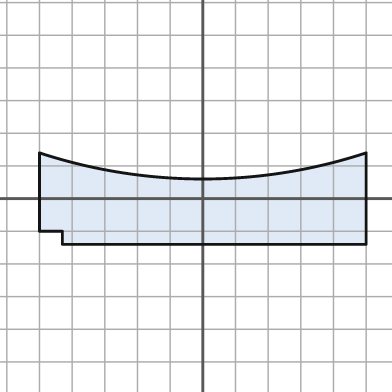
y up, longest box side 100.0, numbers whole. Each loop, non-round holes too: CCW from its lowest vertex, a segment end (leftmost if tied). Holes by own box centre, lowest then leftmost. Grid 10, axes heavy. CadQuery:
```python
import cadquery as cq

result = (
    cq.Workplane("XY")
    .moveTo(-43.0, -14.0)
    .lineTo(50.0, -14.0)
    .lineTo(50.0, 14.0)
    .threePointArc((0.0, 6.0), (-50.0, 14.0))
    .lineTo(-50.0, -10.0)
    .lineTo(-43.0, -10.0)
    .close()
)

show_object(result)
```